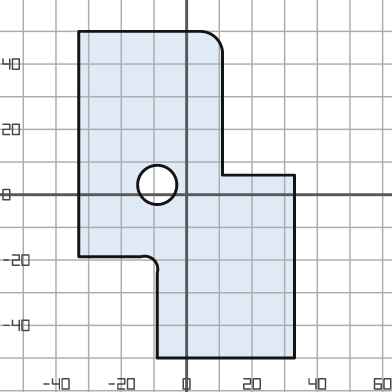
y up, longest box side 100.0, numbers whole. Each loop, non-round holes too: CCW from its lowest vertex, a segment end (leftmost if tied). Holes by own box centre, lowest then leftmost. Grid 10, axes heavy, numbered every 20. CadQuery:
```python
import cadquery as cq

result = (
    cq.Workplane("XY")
    .moveTo(-9.0, -50.0)
    .lineTo(33.0, -50.0)
    .lineTo(33.0, 6.0)
    .lineTo(11.0, 6.0)
    .lineTo(11.0, 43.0)
    .threePointArc((9.0, 48.0), (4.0, 50.0))
    .lineTo(-33.0, 50.0)
    .lineTo(-33.0, -19.0)
    .lineTo(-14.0, -19.0)
    .threePointArc((-10.0, -20.0), (-9.0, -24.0))
    .close()
    .moveTo(-9.0, 3.0)
    .circle(6.0)
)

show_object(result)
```